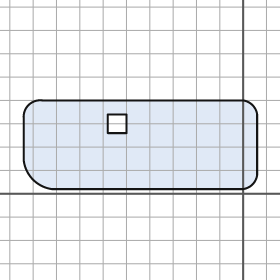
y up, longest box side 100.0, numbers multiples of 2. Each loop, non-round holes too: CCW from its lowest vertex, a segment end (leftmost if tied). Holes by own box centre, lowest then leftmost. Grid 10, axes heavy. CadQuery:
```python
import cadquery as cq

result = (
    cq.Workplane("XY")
    .moveTo(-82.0, 2.0)
    .lineTo(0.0, 2.0)
    .threePointArc((4.0, 4.0), (6.0, 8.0))
    .lineTo(6.0, 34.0)
    .threePointArc((4.0, 38.0), (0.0, 40.0))
    .lineTo(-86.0, 40.0)
    .threePointArc((-92.0, 38.0), (-94.0, 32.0))
    .lineTo(-94.0, 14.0)
    .threePointArc((-90.0, 6.0), (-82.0, 2.0))
    .close()
    .moveTo(-58.0, 26.0)
    .lineTo(-50.0, 26.0)
    .lineTo(-50.0, 34.0)
    .lineTo(-58.0, 34.0)
    .close()
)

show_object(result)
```